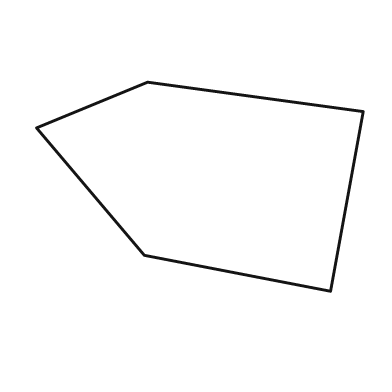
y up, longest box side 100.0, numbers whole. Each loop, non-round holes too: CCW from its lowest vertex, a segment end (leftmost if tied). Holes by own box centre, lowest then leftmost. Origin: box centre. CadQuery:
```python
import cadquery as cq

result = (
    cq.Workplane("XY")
    .moveTo(40.0, -32.0)
    .lineTo(50.0, 23.0)
    .lineTo(-16.0, 32.0)
    .lineTo(-50.0, 18.0)
    .lineTo(-17.0, -21.0)
    .close()
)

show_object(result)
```